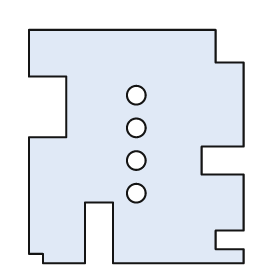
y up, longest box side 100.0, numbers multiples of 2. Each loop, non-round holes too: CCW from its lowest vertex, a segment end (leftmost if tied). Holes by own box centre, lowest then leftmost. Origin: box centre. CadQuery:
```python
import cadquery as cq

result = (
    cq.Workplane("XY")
    .moveTo(-40.0, -50.0)
    .lineTo(-22.0, -50.0)
    .lineTo(-22.0, -24.0)
    .lineTo(-10.0, -24.0)
    .lineTo(-10.0, -50.0)
    .lineTo(46.0, -50.0)
    .lineTo(46.0, -44.0)
    .lineTo(34.0, -44.0)
    .lineTo(34.0, -36.0)
    .lineTo(46.0, -36.0)
    .lineTo(46.0, -12.0)
    .lineTo(28.0, -12.0)
    .lineTo(28.0, 0.0)
    .lineTo(46.0, 0.0)
    .lineTo(46.0, 36.0)
    .lineTo(34.0, 36.0)
    .lineTo(34.0, 50.0)
    .lineTo(-46.0, 50.0)
    .lineTo(-46.0, 30.0)
    .lineTo(-30.0, 30.0)
    .lineTo(-30.0, 4.0)
    .lineTo(-46.0, 4.0)
    .lineTo(-46.0, -46.0)
    .lineTo(-40.0, -46.0)
    .close()
    .moveTo(0.0, -20.0)
    .circle(4.0)
    .moveTo(0.0, -6.0)
    .circle(4.0)
    .moveTo(0.0, 8.0)
    .circle(4.0)
    .moveTo(0.0, 22.0)
    .circle(4.0)
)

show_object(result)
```